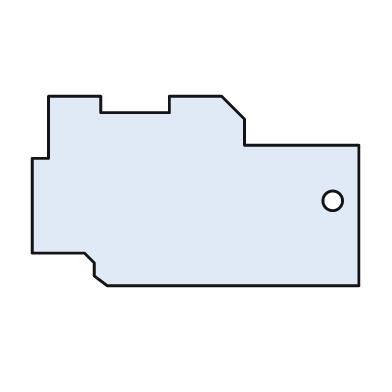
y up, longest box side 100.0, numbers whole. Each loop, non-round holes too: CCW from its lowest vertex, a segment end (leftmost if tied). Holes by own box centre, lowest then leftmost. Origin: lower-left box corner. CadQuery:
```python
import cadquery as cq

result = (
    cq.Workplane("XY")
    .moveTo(23.0, 0.0)
    .lineTo(100.0, 0.0)
    .lineTo(100.0, 43.0)
    .lineTo(65.0, 43.0)
    .lineTo(65.0, 51.0)
    .lineTo(58.0, 58.0)
    .lineTo(42.0, 58.0)
    .lineTo(42.0, 53.0)
    .lineTo(21.0, 53.0)
    .lineTo(21.0, 58.0)
    .lineTo(5.0, 58.0)
    .lineTo(5.0, 39.0)
    .lineTo(0.0, 39.0)
    .lineTo(0.0, 10.0)
    .lineTo(16.0, 10.0)
    .lineTo(19.0, 7.0)
    .lineTo(19.0, 3.0)
    .close()
    .moveTo(92.0, 26.0)
    .circle(3.0)
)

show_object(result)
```